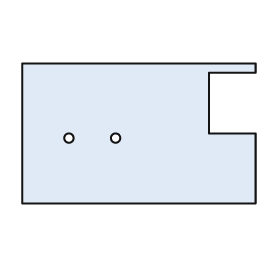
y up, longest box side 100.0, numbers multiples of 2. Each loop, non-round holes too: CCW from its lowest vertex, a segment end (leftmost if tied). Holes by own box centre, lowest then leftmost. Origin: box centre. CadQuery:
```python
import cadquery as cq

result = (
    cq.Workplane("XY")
    .moveTo(-50.0, -30.0)
    .lineTo(50.0, -30.0)
    .lineTo(50.0, 0.0)
    .lineTo(30.0, 0.0)
    .lineTo(30.0, 26.0)
    .lineTo(50.0, 26.0)
    .lineTo(50.0, 30.0)
    .lineTo(-50.0, 30.0)
    .close()
    .moveTo(-30.0, -2.0)
    .circle(2.0)
    .moveTo(-10.0, -2.0)
    .circle(2.0)
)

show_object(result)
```